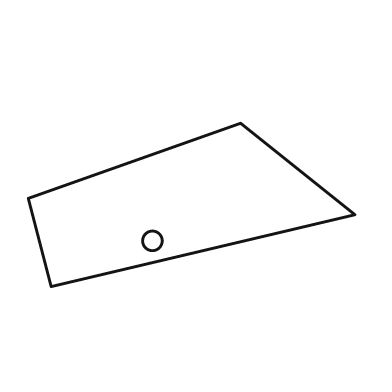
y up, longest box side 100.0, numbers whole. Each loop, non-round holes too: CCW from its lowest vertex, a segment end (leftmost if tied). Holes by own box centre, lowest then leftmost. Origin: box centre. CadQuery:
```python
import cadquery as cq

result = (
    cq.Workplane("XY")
    .moveTo(-43.0, -25.0)
    .lineTo(50.0, -3.0)
    .lineTo(15.0, 25.0)
    .lineTo(-50.0, 2.0)
    .close()
    .moveTo(-12.0, -11.0)
    .circle(3.0)
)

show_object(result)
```